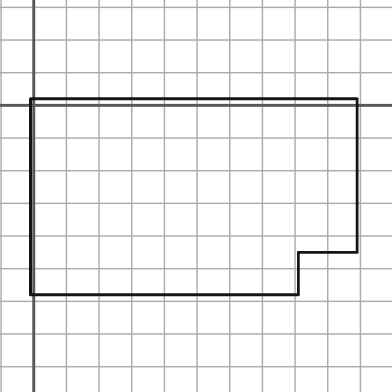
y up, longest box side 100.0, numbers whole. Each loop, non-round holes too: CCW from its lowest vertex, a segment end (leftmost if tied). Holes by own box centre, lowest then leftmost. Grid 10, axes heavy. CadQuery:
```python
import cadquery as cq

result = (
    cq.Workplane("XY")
    .moveTo(-1.0, -58.0)
    .lineTo(81.0, -58.0)
    .lineTo(81.0, -45.0)
    .lineTo(99.0, -45.0)
    .lineTo(99.0, 2.0)
    .lineTo(-1.0, 2.0)
    .close()
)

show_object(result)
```